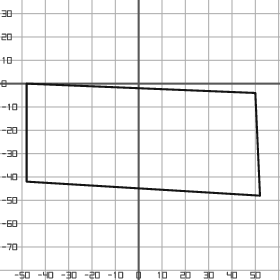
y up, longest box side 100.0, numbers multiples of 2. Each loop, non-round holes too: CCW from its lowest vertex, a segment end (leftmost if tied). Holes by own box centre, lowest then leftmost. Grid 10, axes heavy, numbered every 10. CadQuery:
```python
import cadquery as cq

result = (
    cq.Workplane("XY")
    .moveTo(52.0, -48.0)
    .lineTo(50.0, -4.0)
    .lineTo(-48.0, 0.0)
    .lineTo(-48.0, -42.0)
    .close()
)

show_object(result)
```